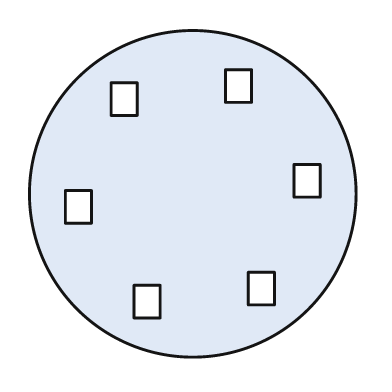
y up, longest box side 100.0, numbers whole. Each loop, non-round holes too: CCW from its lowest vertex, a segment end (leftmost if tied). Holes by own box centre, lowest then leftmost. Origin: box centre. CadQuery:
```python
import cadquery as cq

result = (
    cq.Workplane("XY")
    .moveTo(0.0, 0.0)
    .circle(50.0)
    .moveTo(-18.0, -38.0)
    .lineTo(-10.0, -38.0)
    .lineTo(-10.0, -28.0)
    .lineTo(-18.0, -28.0)
    .close()
    .moveTo(17.0, -34.0)
    .lineTo(25.0, -34.0)
    .lineTo(25.0, -24.0)
    .lineTo(17.0, -24.0)
    .close()
    .moveTo(-39.0, -9.0)
    .lineTo(-31.0, -9.0)
    .lineTo(-31.0, 1.0)
    .lineTo(-39.0, 1.0)
    .close()
    .moveTo(31.0, -1.0)
    .lineTo(39.0, -1.0)
    .lineTo(39.0, 9.0)
    .lineTo(31.0, 9.0)
    .close()
    .moveTo(-25.0, 24.0)
    .lineTo(-17.0, 24.0)
    .lineTo(-17.0, 34.0)
    .lineTo(-25.0, 34.0)
    .close()
    .moveTo(10.0, 28.0)
    .lineTo(18.0, 28.0)
    .lineTo(18.0, 38.0)
    .lineTo(10.0, 38.0)
    .close()
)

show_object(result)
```